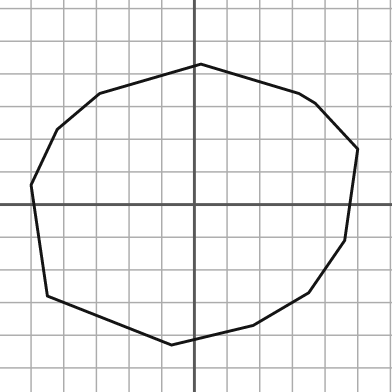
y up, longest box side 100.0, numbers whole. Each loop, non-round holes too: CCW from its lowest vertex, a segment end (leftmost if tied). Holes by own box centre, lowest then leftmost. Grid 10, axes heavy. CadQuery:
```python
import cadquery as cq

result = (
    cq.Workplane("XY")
    .moveTo(-7.0, -43.0)
    .lineTo(18.0, -37.0)
    .lineTo(35.0, -27.0)
    .lineTo(46.0, -11.0)
    .lineTo(50.0, 17.0)
    .lineTo(37.0, 31.0)
    .lineTo(32.0, 34.0)
    .lineTo(2.0, 43.0)
    .lineTo(-29.0, 34.0)
    .lineTo(-42.0, 23.0)
    .lineTo(-50.0, 6.0)
    .lineTo(-45.0, -28.0)
    .close()
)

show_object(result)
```